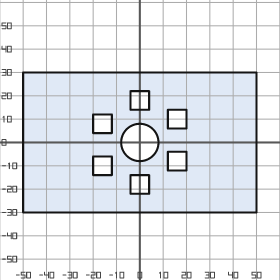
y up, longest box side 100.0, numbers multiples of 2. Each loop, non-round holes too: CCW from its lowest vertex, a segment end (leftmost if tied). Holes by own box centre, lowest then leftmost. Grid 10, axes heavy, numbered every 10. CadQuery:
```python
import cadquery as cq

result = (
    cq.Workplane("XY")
    .moveTo(-50.0, -30.0)
    .lineTo(50.0, -30.0)
    .lineTo(50.0, 30.0)
    .lineTo(-50.0, 30.0)
    .close()
    .moveTo(-4.0, -22.0)
    .lineTo(4.0, -22.0)
    .lineTo(4.0, -14.0)
    .lineTo(-4.0, -14.0)
    .close()
    .moveTo(-20.0, -14.0)
    .lineTo(-12.0, -14.0)
    .lineTo(-12.0, -6.0)
    .lineTo(-20.0, -6.0)
    .close()
    .moveTo(12.0, -12.0)
    .lineTo(20.0, -12.0)
    .lineTo(20.0, -4.0)
    .lineTo(12.0, -4.0)
    .close()
    .moveTo(0.0, 0.0)
    .circle(8.0)
    .moveTo(-20.0, 4.0)
    .lineTo(-12.0, 4.0)
    .lineTo(-12.0, 12.0)
    .lineTo(-20.0, 12.0)
    .close()
    .moveTo(12.0, 6.0)
    .lineTo(20.0, 6.0)
    .lineTo(20.0, 14.0)
    .lineTo(12.0, 14.0)
    .close()
    .moveTo(-4.0, 14.0)
    .lineTo(4.0, 14.0)
    .lineTo(4.0, 22.0)
    .lineTo(-4.0, 22.0)
    .close()
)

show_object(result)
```